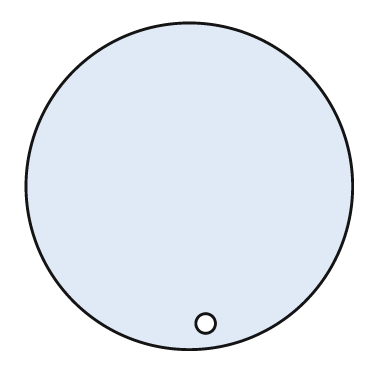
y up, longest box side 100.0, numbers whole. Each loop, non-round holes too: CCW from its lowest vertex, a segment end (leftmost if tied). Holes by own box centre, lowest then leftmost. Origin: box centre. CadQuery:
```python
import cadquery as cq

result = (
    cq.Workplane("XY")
    .moveTo(0.0, 0.0)
    .circle(50.0)
    .moveTo(5.0, -42.0)
    .circle(3.0)
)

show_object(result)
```